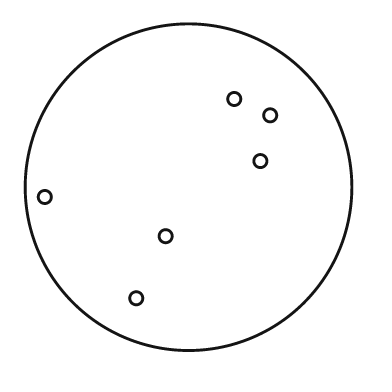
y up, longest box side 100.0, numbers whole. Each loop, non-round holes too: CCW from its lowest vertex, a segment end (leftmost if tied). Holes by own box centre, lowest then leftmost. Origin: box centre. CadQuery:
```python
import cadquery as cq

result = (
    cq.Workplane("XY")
    .moveTo(0.0, 0.0)
    .circle(50.0)
    .moveTo(-16.0, -34.0)
    .circle(2.0)
    .moveTo(-7.0, -15.0)
    .circle(2.0)
    .moveTo(-44.0, -3.0)
    .circle(2.0)
    .moveTo(22.0, 8.0)
    .circle(2.0)
    .moveTo(25.0, 22.0)
    .circle(2.0)
    .moveTo(14.0, 27.0)
    .circle(2.0)
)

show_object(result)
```